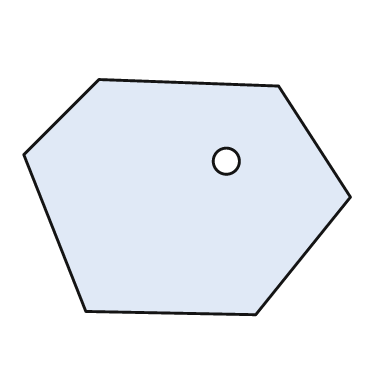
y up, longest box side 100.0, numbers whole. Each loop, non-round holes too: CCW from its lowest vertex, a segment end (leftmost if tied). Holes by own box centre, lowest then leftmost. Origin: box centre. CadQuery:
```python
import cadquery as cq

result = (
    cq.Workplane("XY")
    .moveTo(21.0, -36.0)
    .lineTo(50.0, 0.0)
    .lineTo(28.0, 34.0)
    .lineTo(-27.0, 36.0)
    .lineTo(-50.0, 13.0)
    .lineTo(-31.0, -35.0)
    .close()
    .moveTo(12.0, 11.0)
    .circle(4.0)
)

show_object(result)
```